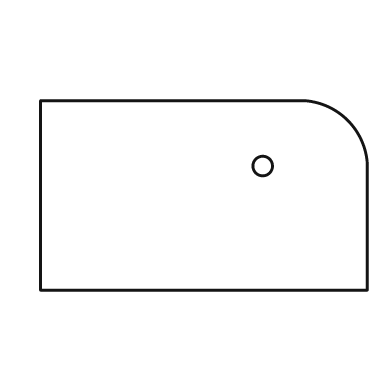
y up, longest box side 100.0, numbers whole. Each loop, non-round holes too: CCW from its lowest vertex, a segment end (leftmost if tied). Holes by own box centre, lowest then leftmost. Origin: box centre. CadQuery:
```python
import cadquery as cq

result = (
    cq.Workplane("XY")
    .moveTo(-50.0, -29.0)
    .lineTo(50.0, -29.0)
    .lineTo(50.0, 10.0)
    .threePointArc((44.0, 23.0), (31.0, 29.0))
    .lineTo(-50.0, 29.0)
    .close()
    .moveTo(18.0, 9.0)
    .circle(3.0)
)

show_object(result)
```